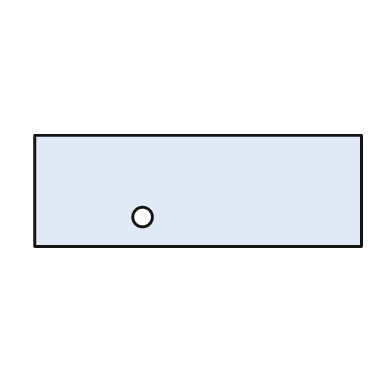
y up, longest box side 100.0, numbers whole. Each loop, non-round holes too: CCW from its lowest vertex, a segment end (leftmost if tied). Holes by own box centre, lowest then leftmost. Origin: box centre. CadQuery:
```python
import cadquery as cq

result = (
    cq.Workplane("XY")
    .moveTo(-50.0, -17.0)
    .lineTo(50.0, -17.0)
    .lineTo(50.0, 17.0)
    .lineTo(-50.0, 17.0)
    .close()
    .moveTo(-17.0, -8.0)
    .circle(3.0)
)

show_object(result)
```